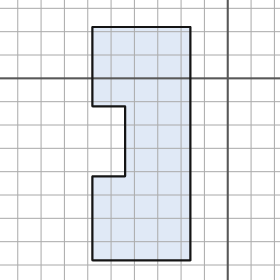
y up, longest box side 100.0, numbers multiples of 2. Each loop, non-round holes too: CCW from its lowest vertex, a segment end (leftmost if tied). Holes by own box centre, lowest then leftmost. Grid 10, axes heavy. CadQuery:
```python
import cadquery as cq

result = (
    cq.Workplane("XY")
    .moveTo(-58.0, -78.0)
    .lineTo(-16.0, -78.0)
    .lineTo(-16.0, 22.0)
    .lineTo(-58.0, 22.0)
    .lineTo(-58.0, -12.0)
    .lineTo(-44.0, -12.0)
    .lineTo(-44.0, -42.0)
    .lineTo(-58.0, -42.0)
    .close()
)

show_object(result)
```